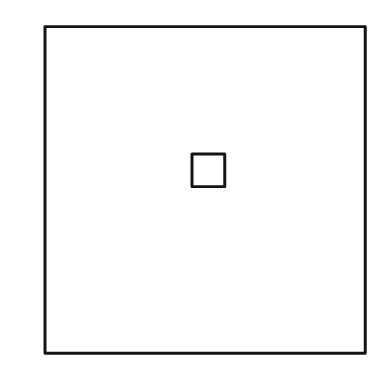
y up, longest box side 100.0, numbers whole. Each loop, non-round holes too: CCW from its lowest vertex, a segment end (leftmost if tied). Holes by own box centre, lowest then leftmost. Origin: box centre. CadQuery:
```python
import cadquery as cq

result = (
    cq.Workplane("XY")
    .moveTo(-49.0, -50.0)
    .lineTo(49.0, -50.0)
    .lineTo(49.0, 50.0)
    .lineTo(-49.0, 50.0)
    .close()
    .moveTo(-4.0, 1.0)
    .lineTo(6.0, 1.0)
    .lineTo(6.0, 11.0)
    .lineTo(-4.0, 11.0)
    .close()
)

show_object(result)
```